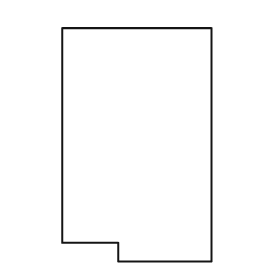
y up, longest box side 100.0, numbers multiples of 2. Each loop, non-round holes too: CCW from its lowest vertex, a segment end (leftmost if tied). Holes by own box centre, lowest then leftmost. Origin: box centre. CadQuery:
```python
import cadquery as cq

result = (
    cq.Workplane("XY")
    .moveTo(-8.0, -50.0)
    .lineTo(32.0, -50.0)
    .lineTo(32.0, 50.0)
    .lineTo(-32.0, 50.0)
    .lineTo(-32.0, -42.0)
    .lineTo(-8.0, -42.0)
    .close()
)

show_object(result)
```